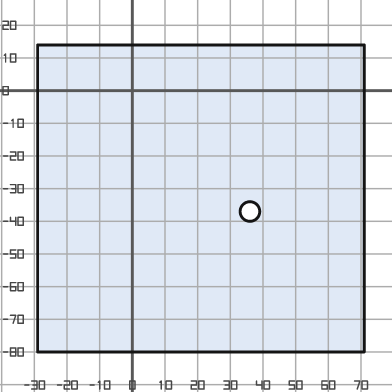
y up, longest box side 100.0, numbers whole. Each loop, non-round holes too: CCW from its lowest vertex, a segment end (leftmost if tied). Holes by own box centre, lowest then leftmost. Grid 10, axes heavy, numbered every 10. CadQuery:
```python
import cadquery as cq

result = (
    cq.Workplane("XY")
    .moveTo(-29.0, -80.0)
    .lineTo(71.0, -80.0)
    .lineTo(71.0, 14.0)
    .lineTo(-29.0, 14.0)
    .close()
    .moveTo(36.0, -37.0)
    .circle(3.0)
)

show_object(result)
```